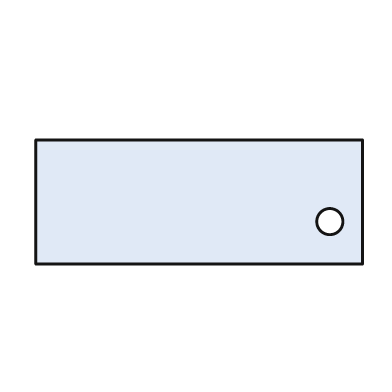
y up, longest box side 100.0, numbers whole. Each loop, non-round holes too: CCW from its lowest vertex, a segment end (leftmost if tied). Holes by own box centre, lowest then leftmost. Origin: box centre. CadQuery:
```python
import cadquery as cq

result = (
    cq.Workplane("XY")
    .moveTo(-50.0, -19.0)
    .lineTo(50.0, -19.0)
    .lineTo(50.0, 19.0)
    .lineTo(-50.0, 19.0)
    .close()
    .moveTo(40.0, -6.0)
    .circle(4.0)
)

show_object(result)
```